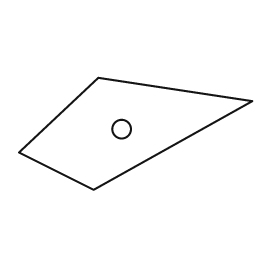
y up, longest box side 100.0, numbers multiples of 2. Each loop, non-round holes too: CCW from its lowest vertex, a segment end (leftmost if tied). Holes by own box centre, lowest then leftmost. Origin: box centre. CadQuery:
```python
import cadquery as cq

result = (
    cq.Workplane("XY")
    .moveTo(-18.0, -24.0)
    .lineTo(50.0, 14.0)
    .lineTo(-16.0, 24.0)
    .lineTo(-50.0, -8.0)
    .close()
    .moveTo(-6.0, 2.0)
    .circle(4.0)
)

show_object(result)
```